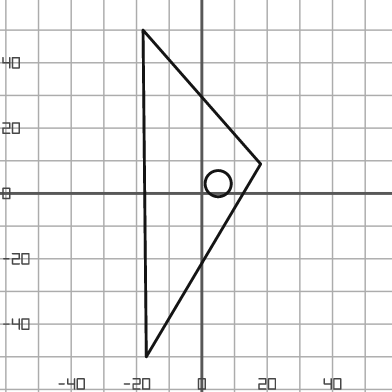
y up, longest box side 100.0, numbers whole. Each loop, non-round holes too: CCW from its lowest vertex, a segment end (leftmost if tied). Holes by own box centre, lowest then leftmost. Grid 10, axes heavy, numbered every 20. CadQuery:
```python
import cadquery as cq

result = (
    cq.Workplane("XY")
    .moveTo(-17.0, -50.0)
    .lineTo(18.0, 9.0)
    .lineTo(-18.0, 50.0)
    .close()
    .moveTo(5.0, 3.0)
    .circle(4.0)
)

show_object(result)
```